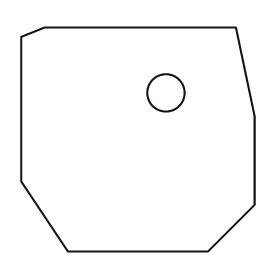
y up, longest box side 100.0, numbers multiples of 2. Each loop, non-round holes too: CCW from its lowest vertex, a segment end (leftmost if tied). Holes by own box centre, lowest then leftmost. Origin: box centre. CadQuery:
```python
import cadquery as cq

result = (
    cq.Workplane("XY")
    .moveTo(-30.0, -48.0)
    .lineTo(30.0, -48.0)
    .lineTo(50.0, -28.0)
    .lineTo(50.0, 10.0)
    .lineTo(42.0, 48.0)
    .lineTo(-40.0, 48.0)
    .lineTo(-50.0, 44.0)
    .lineTo(-50.0, -18.0)
    .close()
    .moveTo(12.0, 20.0)
    .circle(8.0)
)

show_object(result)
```